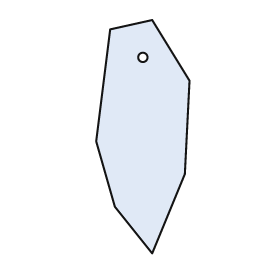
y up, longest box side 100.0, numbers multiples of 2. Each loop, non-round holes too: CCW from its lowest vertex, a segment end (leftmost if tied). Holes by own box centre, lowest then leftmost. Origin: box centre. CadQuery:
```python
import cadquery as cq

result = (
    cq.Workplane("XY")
    .moveTo(4.0, -50.0)
    .lineTo(18.0, -16.0)
    .lineTo(20.0, 24.0)
    .lineTo(4.0, 50.0)
    .lineTo(-14.0, 46.0)
    .lineTo(-20.0, -2.0)
    .lineTo(-12.0, -30.0)
    .close()
    .moveTo(0.0, 34.0)
    .circle(2.0)
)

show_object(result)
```